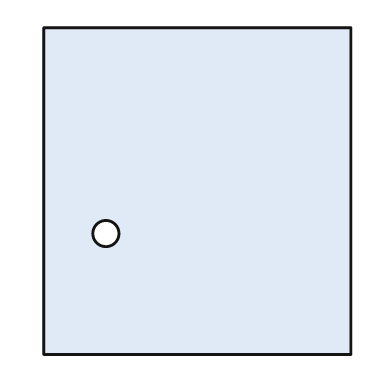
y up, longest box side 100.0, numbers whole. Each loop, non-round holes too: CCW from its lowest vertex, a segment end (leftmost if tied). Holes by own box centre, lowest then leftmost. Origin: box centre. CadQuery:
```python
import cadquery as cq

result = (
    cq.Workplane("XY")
    .moveTo(-47.0, -50.0)
    .lineTo(47.0, -50.0)
    .lineTo(47.0, 50.0)
    .lineTo(-47.0, 50.0)
    .close()
    .moveTo(-28.0, -13.0)
    .circle(4.0)
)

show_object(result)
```